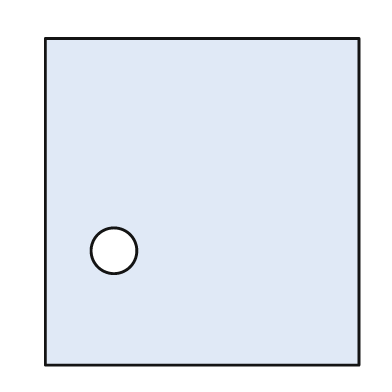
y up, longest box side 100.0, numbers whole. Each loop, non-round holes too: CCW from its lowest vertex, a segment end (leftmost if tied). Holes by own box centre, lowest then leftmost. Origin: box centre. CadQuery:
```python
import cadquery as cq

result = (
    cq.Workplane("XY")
    .moveTo(-48.0, -50.0)
    .lineTo(48.0, -50.0)
    .lineTo(48.0, 50.0)
    .lineTo(-48.0, 50.0)
    .close()
    .moveTo(-27.0, -15.0)
    .circle(7.0)
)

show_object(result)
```